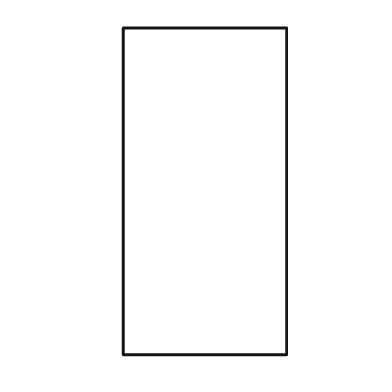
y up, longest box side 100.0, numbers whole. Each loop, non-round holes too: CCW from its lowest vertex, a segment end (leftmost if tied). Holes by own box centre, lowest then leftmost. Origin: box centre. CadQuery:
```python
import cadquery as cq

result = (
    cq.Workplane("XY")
    .moveTo(-25.0, -50.0)
    .lineTo(25.0, -50.0)
    .lineTo(25.0, 50.0)
    .lineTo(-25.0, 50.0)
    .close()
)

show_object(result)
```